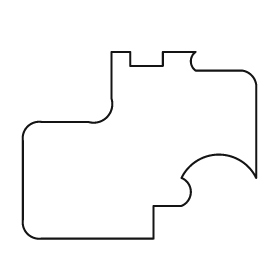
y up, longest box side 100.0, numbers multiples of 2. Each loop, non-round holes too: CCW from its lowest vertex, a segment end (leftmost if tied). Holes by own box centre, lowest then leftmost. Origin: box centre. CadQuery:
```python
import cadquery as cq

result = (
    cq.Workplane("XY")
    .moveTo(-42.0, -40.0)
    .lineTo(6.0, -40.0)
    .lineTo(6.0, -26.0)
    .lineTo(18.0, -26.0)
    .threePointArc((22.0, -20.0), (18.0, -14.0))
    .threePointArc((34.0, -4.0), (50.0, -14.0))
    .lineTo(50.0, 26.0)
    .threePointArc((48.0, 30.0), (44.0, 32.0))
    .lineTo(24.0, 32.0)
    .threePointArc((22.0, 36.0), (24.0, 40.0))
    .lineTo(10.0, 40.0)
    .lineTo(10.0, 34.0)
    .lineTo(-4.0, 34.0)
    .lineTo(-4.0, 40.0)
    .lineTo(-12.0, 40.0)
    .lineTo(-12.0, 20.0)
    .threePointArc((-14.0, 12.0), (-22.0, 10.0))
    .lineTo(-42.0, 10.0)
    .threePointArc((-48.0, 8.0), (-50.0, 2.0))
    .lineTo(-50.0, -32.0)
    .threePointArc((-48.0, -38.0), (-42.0, -40.0))
    .close()
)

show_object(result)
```